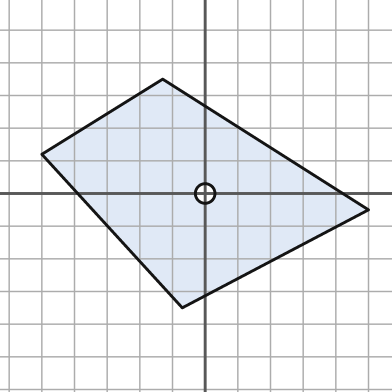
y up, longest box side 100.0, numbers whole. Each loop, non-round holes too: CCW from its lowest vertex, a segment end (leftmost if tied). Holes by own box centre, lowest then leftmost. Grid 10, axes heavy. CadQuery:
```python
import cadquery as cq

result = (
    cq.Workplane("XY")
    .moveTo(-7.0, -35.0)
    .lineTo(50.0, -5.0)
    .lineTo(-13.0, 35.0)
    .lineTo(-50.0, 12.0)
    .close()
    .moveTo(0.0, 0.0)
    .circle(3.0)
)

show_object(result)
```